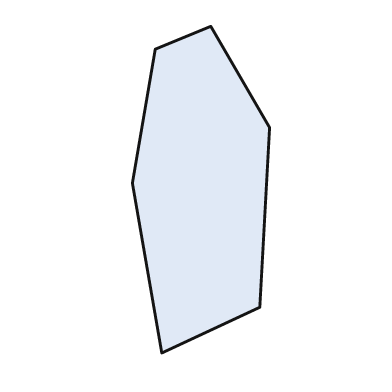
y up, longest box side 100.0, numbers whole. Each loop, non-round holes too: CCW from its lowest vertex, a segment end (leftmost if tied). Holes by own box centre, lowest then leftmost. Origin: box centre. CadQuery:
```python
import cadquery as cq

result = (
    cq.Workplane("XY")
    .moveTo(-12.0, -50.0)
    .lineTo(18.0, -36.0)
    .lineTo(21.0, 19.0)
    .lineTo(3.0, 50.0)
    .lineTo(-14.0, 43.0)
    .lineTo(-21.0, 2.0)
    .close()
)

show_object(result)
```